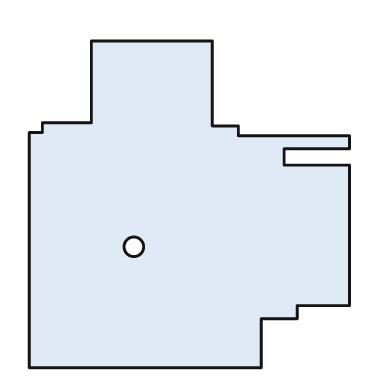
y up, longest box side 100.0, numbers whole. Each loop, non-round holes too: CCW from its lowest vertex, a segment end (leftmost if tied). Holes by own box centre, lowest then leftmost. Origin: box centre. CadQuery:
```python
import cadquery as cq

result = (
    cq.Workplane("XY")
    .moveTo(-49.0, -50.0)
    .lineTo(22.0, -50.0)
    .lineTo(22.0, -35.0)
    .lineTo(33.0, -35.0)
    .lineTo(33.0, -31.0)
    .lineTo(49.0, -31.0)
    .lineTo(49.0, 12.0)
    .lineTo(29.0, 12.0)
    .lineTo(29.0, 17.0)
    .lineTo(49.0, 17.0)
    .lineTo(49.0, 21.0)
    .lineTo(15.0, 21.0)
    .lineTo(15.0, 24.0)
    .lineTo(7.0, 24.0)
    .lineTo(7.0, 50.0)
    .lineTo(-30.0, 50.0)
    .lineTo(-30.0, 25.0)
    .lineTo(-45.0, 25.0)
    .lineTo(-45.0, 22.0)
    .lineTo(-49.0, 22.0)
    .close()
    .moveTo(-17.0, -13.0)
    .circle(3.0)
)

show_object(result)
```